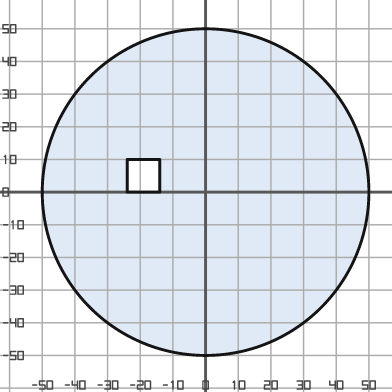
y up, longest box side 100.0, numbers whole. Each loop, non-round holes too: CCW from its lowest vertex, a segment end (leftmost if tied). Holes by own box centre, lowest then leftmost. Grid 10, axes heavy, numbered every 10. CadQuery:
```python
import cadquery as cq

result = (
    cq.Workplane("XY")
    .moveTo(0.0, 0.0)
    .circle(50.0)
    .moveTo(-24.0, 0.0)
    .lineTo(-14.0, 0.0)
    .lineTo(-14.0, 10.0)
    .lineTo(-24.0, 10.0)
    .close()
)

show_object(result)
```